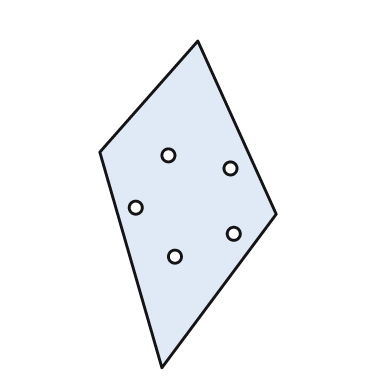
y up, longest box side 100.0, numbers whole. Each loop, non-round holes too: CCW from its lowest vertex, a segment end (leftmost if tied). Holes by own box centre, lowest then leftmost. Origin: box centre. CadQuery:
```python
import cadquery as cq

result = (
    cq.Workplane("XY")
    .moveTo(-8.0, -50.0)
    .lineTo(27.0, -3.0)
    .lineTo(3.0, 50.0)
    .lineTo(-27.0, 16.0)
    .close()
    .moveTo(-4.0, -16.0)
    .circle(2.0)
    .moveTo(14.0, -9.0)
    .circle(2.0)
    .moveTo(-16.0, -1.0)
    .circle(2.0)
    .moveTo(13.0, 11.0)
    .circle(2.0)
    .moveTo(-6.0, 15.0)
    .circle(2.0)
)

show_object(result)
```